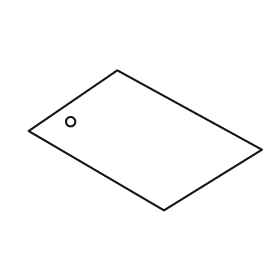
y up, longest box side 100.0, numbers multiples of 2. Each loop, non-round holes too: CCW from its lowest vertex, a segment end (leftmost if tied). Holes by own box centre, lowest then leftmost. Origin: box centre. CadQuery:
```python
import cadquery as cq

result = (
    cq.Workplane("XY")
    .moveTo(8.0, -30.0)
    .lineTo(50.0, -4.0)
    .lineTo(-12.0, 30.0)
    .lineTo(-50.0, 4.0)
    .close()
    .moveTo(-32.0, 8.0)
    .circle(2.0)
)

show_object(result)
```